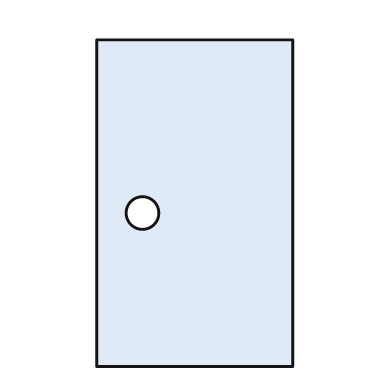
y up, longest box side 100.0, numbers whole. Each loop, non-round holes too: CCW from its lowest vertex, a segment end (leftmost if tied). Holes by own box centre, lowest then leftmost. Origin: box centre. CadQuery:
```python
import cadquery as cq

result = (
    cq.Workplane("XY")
    .moveTo(-30.0, -50.0)
    .lineTo(30.0, -50.0)
    .lineTo(30.0, 50.0)
    .lineTo(-30.0, 50.0)
    .close()
    .moveTo(-16.0, -3.0)
    .circle(5.0)
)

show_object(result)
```